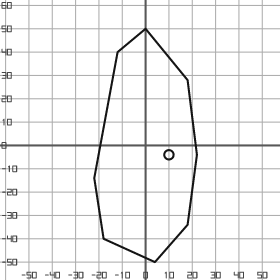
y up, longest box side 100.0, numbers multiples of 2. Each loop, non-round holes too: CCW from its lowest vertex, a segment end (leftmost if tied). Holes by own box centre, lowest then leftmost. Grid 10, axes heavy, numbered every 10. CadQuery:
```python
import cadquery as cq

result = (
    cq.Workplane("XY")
    .moveTo(4.0, -50.0)
    .lineTo(18.0, -34.0)
    .lineTo(22.0, -4.0)
    .lineTo(18.0, 28.0)
    .lineTo(0.0, 50.0)
    .lineTo(-12.0, 40.0)
    .lineTo(-22.0, -14.0)
    .lineTo(-18.0, -40.0)
    .close()
    .moveTo(10.0, -4.0)
    .circle(2.0)
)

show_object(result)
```